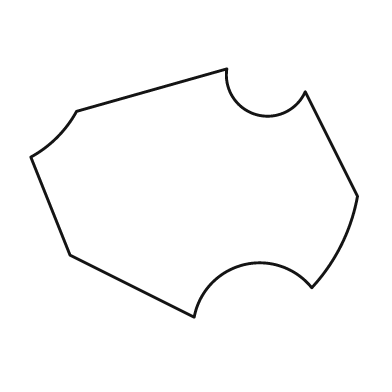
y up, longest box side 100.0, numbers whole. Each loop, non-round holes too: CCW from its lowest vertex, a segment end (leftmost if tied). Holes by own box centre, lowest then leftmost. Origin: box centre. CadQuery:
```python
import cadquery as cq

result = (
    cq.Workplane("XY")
    .moveTo(0.0, -38.0)
    .threePointArc((15.0, -22.0), (36.0, -29.0))
    .threePointArc((45.0, -16.0), (50.0, -1.0))
    .lineTo(34.0, 31.0)
    .threePointArc((19.0, 24.0), (10.0, 38.0))
    .lineTo(-36.0, 25.0)
    .threePointArc((-42.0, 17.0), (-50.0, 11.0))
    .lineTo(-38.0, -19.0)
    .close()
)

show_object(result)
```